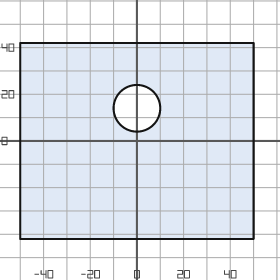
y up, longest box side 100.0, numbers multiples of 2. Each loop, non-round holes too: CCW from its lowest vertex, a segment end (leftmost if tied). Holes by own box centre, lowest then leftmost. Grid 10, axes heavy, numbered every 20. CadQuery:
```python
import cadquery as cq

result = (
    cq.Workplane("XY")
    .moveTo(-50.0, -42.0)
    .lineTo(50.0, -42.0)
    .lineTo(50.0, 42.0)
    .lineTo(-50.0, 42.0)
    .close()
    .moveTo(0.0, 14.0)
    .circle(10.0)
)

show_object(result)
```